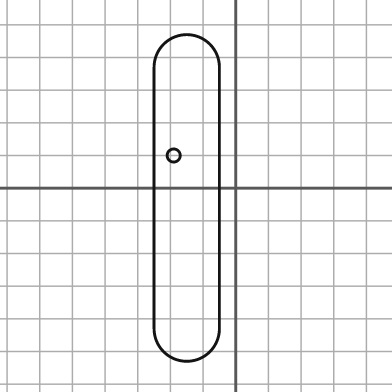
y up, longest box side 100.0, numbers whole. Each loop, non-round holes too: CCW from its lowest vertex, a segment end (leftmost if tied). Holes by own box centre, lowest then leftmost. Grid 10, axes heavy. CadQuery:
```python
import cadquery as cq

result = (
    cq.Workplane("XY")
    .moveTo(-25.0, -43.0)
    .threePointArc((-15.0, -53.0), (-5.0, -43.0))
    .lineTo(-5.0, 37.0)
    .threePointArc((-15.0, 47.0), (-25.0, 37.0))
    .close()
    .moveTo(-19.0, 10.0)
    .circle(2.0)
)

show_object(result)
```